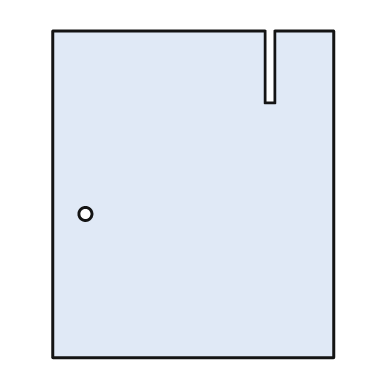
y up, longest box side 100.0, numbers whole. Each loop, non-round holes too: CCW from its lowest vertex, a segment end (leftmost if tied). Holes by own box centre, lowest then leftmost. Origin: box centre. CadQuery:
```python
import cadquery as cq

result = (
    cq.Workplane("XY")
    .moveTo(-43.0, -50.0)
    .lineTo(43.0, -50.0)
    .lineTo(43.0, 50.0)
    .lineTo(25.0, 50.0)
    .lineTo(25.0, 28.0)
    .lineTo(22.0, 28.0)
    .lineTo(22.0, 50.0)
    .lineTo(-43.0, 50.0)
    .close()
    .moveTo(-33.0, -6.0)
    .circle(2.0)
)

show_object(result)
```